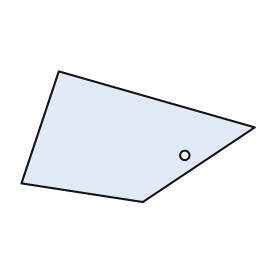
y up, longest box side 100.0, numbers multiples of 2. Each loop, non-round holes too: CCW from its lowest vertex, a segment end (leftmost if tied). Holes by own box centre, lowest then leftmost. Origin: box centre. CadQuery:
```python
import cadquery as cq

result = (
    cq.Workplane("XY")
    .moveTo(2.0, -28.0)
    .lineTo(50.0, 4.0)
    .lineTo(-34.0, 28.0)
    .lineTo(-50.0, -20.0)
    .close()
    .moveTo(20.0, -8.0)
    .circle(2.0)
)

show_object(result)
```